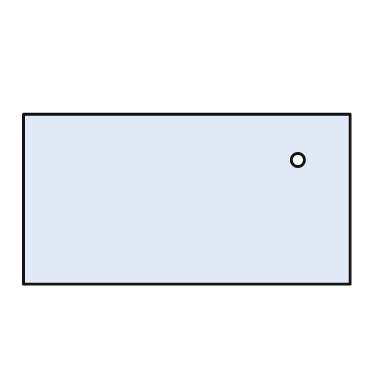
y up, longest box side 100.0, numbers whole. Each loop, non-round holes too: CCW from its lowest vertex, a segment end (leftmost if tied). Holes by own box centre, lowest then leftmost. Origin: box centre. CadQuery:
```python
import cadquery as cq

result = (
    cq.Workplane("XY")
    .moveTo(-50.0, -26.0)
    .lineTo(50.0, -26.0)
    .lineTo(50.0, 26.0)
    .lineTo(-50.0, 26.0)
    .close()
    .moveTo(34.0, 12.0)
    .circle(2.0)
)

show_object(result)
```